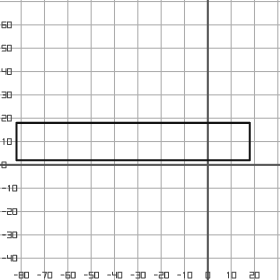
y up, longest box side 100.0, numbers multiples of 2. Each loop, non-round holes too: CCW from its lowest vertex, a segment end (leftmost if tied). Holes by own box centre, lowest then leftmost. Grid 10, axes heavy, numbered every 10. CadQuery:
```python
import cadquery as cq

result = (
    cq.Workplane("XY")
    .moveTo(-82.0, 2.0)
    .lineTo(18.0, 2.0)
    .lineTo(18.0, 18.0)
    .lineTo(-82.0, 18.0)
    .close()
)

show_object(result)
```